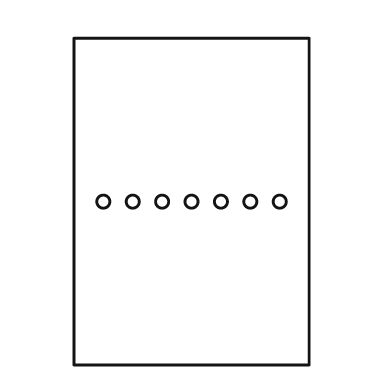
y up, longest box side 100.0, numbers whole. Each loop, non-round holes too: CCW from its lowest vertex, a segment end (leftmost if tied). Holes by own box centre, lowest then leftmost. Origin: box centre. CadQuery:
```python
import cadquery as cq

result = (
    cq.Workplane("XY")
    .moveTo(-36.0, -50.0)
    .lineTo(36.0, -50.0)
    .lineTo(36.0, 50.0)
    .lineTo(-36.0, 50.0)
    .close()
    .moveTo(-27.0, 0.0)
    .circle(2.0)
    .moveTo(-18.0, 0.0)
    .circle(2.0)
    .moveTo(-9.0, 0.0)
    .circle(2.0)
    .moveTo(0.0, 0.0)
    .circle(2.0)
    .moveTo(9.0, 0.0)
    .circle(2.0)
    .moveTo(18.0, 0.0)
    .circle(2.0)
    .moveTo(27.0, 0.0)
    .circle(2.0)
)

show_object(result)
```